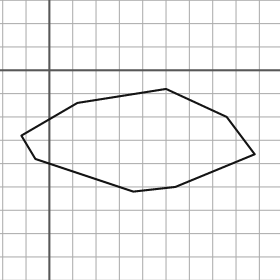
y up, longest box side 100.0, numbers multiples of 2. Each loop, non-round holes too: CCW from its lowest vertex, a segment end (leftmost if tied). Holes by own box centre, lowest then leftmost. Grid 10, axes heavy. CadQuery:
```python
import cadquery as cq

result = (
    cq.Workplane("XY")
    .moveTo(36.0, -52.0)
    .lineTo(54.0, -50.0)
    .lineTo(88.0, -36.0)
    .lineTo(76.0, -20.0)
    .lineTo(50.0, -8.0)
    .lineTo(12.0, -14.0)
    .lineTo(-12.0, -28.0)
    .lineTo(-6.0, -38.0)
    .close()
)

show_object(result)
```